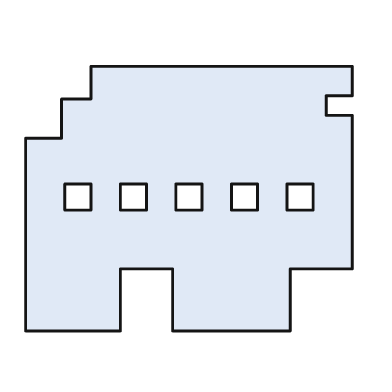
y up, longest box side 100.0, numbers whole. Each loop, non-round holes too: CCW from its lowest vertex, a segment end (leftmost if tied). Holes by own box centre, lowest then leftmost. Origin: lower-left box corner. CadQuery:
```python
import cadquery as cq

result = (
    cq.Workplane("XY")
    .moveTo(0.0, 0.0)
    .lineTo(29.0, 0.0)
    .lineTo(29.0, 19.0)
    .lineTo(45.0, 19.0)
    .lineTo(45.0, 0.0)
    .lineTo(81.0, 0.0)
    .lineTo(81.0, 19.0)
    .lineTo(100.0, 19.0)
    .lineTo(100.0, 66.0)
    .lineTo(92.0, 66.0)
    .lineTo(92.0, 72.0)
    .lineTo(100.0, 72.0)
    .lineTo(100.0, 81.0)
    .lineTo(20.0, 81.0)
    .lineTo(20.0, 71.0)
    .lineTo(11.0, 71.0)
    .lineTo(11.0, 59.0)
    .lineTo(0.0, 59.0)
    .close()
    .moveTo(12.0, 37.0)
    .lineTo(20.0, 37.0)
    .lineTo(20.0, 45.0)
    .lineTo(12.0, 45.0)
    .close()
    .moveTo(29.0, 37.0)
    .lineTo(37.0, 37.0)
    .lineTo(37.0, 45.0)
    .lineTo(29.0, 45.0)
    .close()
    .moveTo(46.0, 37.0)
    .lineTo(54.0, 37.0)
    .lineTo(54.0, 45.0)
    .lineTo(46.0, 45.0)
    .close()
    .moveTo(63.0, 37.0)
    .lineTo(71.0, 37.0)
    .lineTo(71.0, 45.0)
    .lineTo(63.0, 45.0)
    .close()
    .moveTo(80.0, 37.0)
    .lineTo(88.0, 37.0)
    .lineTo(88.0, 45.0)
    .lineTo(80.0, 45.0)
    .close()
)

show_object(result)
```